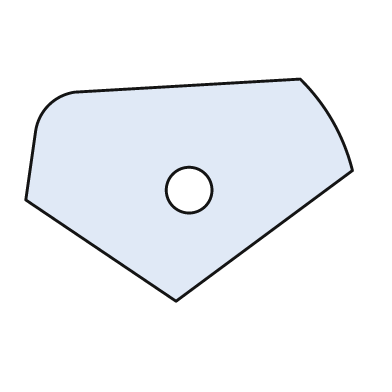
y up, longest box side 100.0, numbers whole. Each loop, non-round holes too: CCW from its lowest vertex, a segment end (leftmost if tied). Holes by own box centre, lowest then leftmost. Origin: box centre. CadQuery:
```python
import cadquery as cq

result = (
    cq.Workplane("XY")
    .moveTo(-4.0, -34.0)
    .lineTo(50.0, 6.0)
    .threePointArc((44.0, 21.0), (34.0, 34.0))
    .lineTo(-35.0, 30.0)
    .threePointArc((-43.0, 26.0), (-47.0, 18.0))
    .lineTo(-50.0, -3.0)
    .close()
    .moveTo(0.0, 0.0)
    .circle(7.0)
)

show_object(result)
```